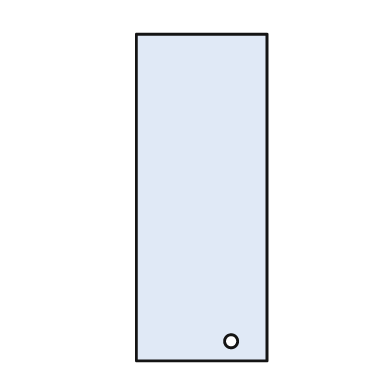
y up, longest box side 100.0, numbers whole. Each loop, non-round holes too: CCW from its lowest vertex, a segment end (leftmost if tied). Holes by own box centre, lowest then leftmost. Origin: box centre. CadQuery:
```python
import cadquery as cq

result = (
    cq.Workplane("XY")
    .moveTo(-20.0, -50.0)
    .lineTo(20.0, -50.0)
    .lineTo(20.0, 50.0)
    .lineTo(-20.0, 50.0)
    .close()
    .moveTo(9.0, -44.0)
    .circle(2.0)
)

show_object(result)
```